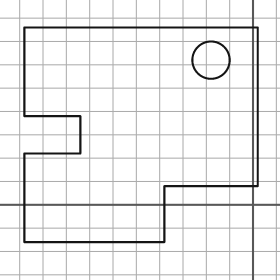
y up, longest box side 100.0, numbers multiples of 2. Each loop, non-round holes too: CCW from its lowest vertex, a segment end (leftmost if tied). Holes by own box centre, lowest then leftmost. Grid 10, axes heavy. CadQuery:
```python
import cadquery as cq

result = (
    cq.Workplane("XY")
    .moveTo(-98.0, -16.0)
    .lineTo(-38.0, -16.0)
    .lineTo(-38.0, 8.0)
    .lineTo(2.0, 8.0)
    .lineTo(2.0, 76.0)
    .lineTo(-98.0, 76.0)
    .lineTo(-98.0, 38.0)
    .lineTo(-74.0, 38.0)
    .lineTo(-74.0, 22.0)
    .lineTo(-98.0, 22.0)
    .close()
    .moveTo(-18.0, 62.0)
    .circle(8.0)
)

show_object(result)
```